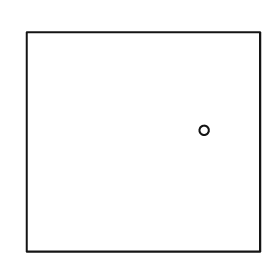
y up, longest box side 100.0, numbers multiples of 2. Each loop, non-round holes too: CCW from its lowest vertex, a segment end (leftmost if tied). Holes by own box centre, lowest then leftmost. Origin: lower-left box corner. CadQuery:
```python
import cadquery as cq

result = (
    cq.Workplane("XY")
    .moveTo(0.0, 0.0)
    .lineTo(100.0, 0.0)
    .lineTo(100.0, 94.0)
    .lineTo(0.0, 94.0)
    .close()
    .moveTo(76.0, 52.0)
    .circle(2.0)
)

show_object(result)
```